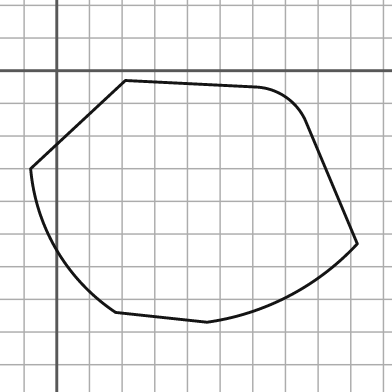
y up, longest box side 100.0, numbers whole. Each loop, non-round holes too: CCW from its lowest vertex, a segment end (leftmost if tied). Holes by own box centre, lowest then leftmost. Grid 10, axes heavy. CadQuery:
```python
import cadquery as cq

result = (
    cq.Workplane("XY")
    .moveTo(46.0, -77.0)
    .threePointArc((71.0, -69.0), (92.0, -53.0))
    .lineTo(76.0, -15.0)
    .threePointArc((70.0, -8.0), (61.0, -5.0))
    .lineTo(21.0, -3.0)
    .lineTo(-8.0, -30.0)
    .threePointArc((0.0, -55.0), (18.0, -74.0))
    .close()
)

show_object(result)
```